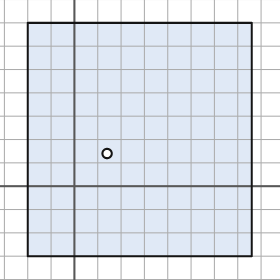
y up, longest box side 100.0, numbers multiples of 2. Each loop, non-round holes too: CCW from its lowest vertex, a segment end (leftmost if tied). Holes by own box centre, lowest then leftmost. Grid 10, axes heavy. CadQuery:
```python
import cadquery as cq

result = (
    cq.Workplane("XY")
    .moveTo(-20.0, -30.0)
    .lineTo(76.0, -30.0)
    .lineTo(76.0, 70.0)
    .lineTo(-20.0, 70.0)
    .close()
    .moveTo(14.0, 14.0)
    .circle(2.0)
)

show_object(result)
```